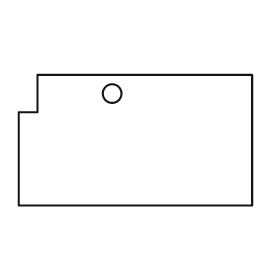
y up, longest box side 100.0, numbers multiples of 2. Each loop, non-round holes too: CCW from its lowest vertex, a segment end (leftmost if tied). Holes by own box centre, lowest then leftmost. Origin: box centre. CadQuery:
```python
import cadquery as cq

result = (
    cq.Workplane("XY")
    .moveTo(-50.0, -28.0)
    .lineTo(50.0, -28.0)
    .lineTo(50.0, 28.0)
    .lineTo(-42.0, 28.0)
    .lineTo(-42.0, 12.0)
    .lineTo(-50.0, 12.0)
    .close()
    .moveTo(-10.0, 20.0)
    .circle(4.0)
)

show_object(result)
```